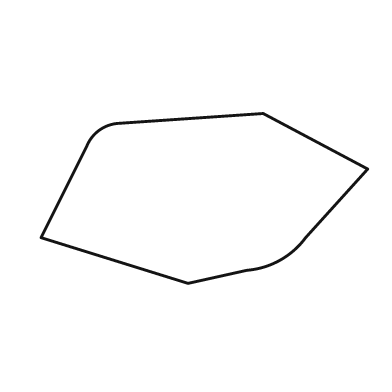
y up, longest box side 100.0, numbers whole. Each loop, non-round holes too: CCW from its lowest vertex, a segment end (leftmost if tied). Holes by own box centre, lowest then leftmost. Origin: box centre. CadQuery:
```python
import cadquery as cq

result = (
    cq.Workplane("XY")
    .moveTo(-5.0, -26.0)
    .lineTo(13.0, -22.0)
    .threePointArc((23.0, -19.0), (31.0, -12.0))
    .lineTo(50.0, 9.0)
    .lineTo(18.0, 26.0)
    .lineTo(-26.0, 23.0)
    .threePointArc((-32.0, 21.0), (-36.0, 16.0))
    .lineTo(-50.0, -12.0)
    .close()
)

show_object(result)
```